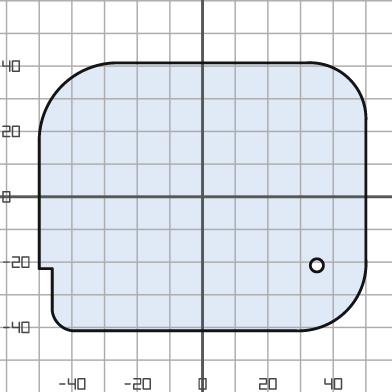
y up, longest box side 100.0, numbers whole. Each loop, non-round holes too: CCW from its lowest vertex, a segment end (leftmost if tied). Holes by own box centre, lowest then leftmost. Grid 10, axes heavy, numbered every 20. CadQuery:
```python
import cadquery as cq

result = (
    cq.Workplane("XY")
    .moveTo(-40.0, -41.0)
    .lineTo(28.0, -41.0)
    .threePointArc((44.0, -35.0), (50.0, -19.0))
    .lineTo(50.0, 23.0)
    .threePointArc((45.0, 36.0), (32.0, 41.0))
    .lineTo(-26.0, 41.0)
    .threePointArc((-43.0, 34.0), (-50.0, 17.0))
    .lineTo(-50.0, -22.0)
    .lineTo(-46.0, -22.0)
    .lineTo(-46.0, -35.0)
    .threePointArc((-44.0, -39.0), (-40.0, -41.0))
    .close()
    .moveTo(35.0, -21.0)
    .circle(2.0)
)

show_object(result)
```